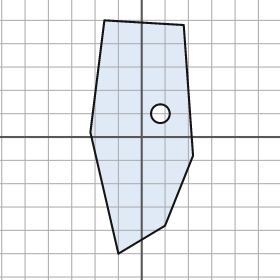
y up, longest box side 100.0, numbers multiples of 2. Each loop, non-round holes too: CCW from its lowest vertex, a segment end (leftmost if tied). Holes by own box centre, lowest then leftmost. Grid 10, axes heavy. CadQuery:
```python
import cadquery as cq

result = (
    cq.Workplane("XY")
    .moveTo(-10.0, -50.0)
    .lineTo(10.0, -38.0)
    .lineTo(22.0, -8.0)
    .lineTo(18.0, 48.0)
    .lineTo(-16.0, 50.0)
    .lineTo(-22.0, 2.0)
    .close()
    .moveTo(8.0, 10.0)
    .circle(4.0)
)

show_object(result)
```